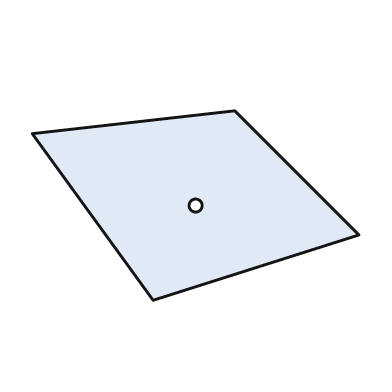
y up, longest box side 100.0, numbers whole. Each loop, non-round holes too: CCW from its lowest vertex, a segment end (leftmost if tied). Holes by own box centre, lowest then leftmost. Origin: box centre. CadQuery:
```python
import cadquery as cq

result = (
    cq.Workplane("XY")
    .moveTo(-13.0, -29.0)
    .lineTo(50.0, -9.0)
    .lineTo(12.0, 29.0)
    .lineTo(-50.0, 22.0)
    .close()
    .moveTo(0.0, 0.0)
    .circle(2.0)
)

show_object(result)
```